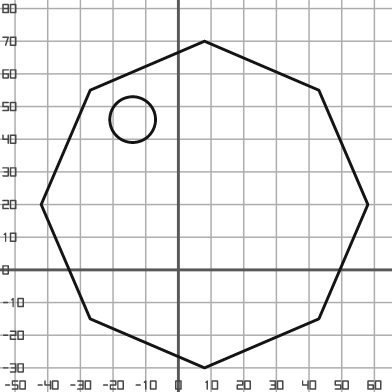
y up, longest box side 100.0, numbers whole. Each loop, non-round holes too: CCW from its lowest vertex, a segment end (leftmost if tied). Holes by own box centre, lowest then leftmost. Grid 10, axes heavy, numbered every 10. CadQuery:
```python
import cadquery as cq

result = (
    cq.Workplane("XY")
    .moveTo(8.0, -30.0)
    .lineTo(43.0, -15.0)
    .lineTo(58.0, 20.0)
    .lineTo(43.0, 55.0)
    .lineTo(8.0, 70.0)
    .lineTo(-27.0, 55.0)
    .lineTo(-42.0, 20.0)
    .lineTo(-27.0, -15.0)
    .close()
    .moveTo(-14.0, 46.0)
    .circle(7.0)
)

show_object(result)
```